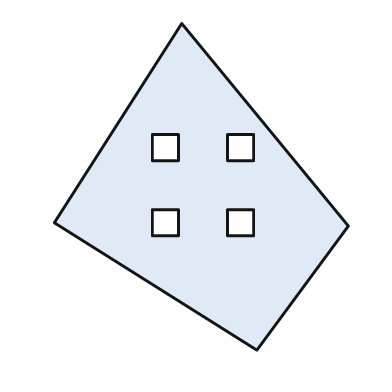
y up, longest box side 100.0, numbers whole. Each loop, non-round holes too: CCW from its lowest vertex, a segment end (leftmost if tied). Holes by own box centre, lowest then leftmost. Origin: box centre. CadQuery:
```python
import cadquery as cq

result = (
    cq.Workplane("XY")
    .moveTo(17.0, -50.0)
    .lineTo(45.0, -12.0)
    .lineTo(-6.0, 50.0)
    .lineTo(-45.0, -11.0)
    .close()
    .moveTo(-15.0, -15.0)
    .lineTo(-7.0, -15.0)
    .lineTo(-7.0, -7.0)
    .lineTo(-15.0, -7.0)
    .close()
    .moveTo(8.0, -15.0)
    .lineTo(16.0, -15.0)
    .lineTo(16.0, -7.0)
    .lineTo(8.0, -7.0)
    .close()
    .moveTo(-15.0, 8.0)
    .lineTo(-7.0, 8.0)
    .lineTo(-7.0, 16.0)
    .lineTo(-15.0, 16.0)
    .close()
    .moveTo(8.0, 8.0)
    .lineTo(16.0, 8.0)
    .lineTo(16.0, 16.0)
    .lineTo(8.0, 16.0)
    .close()
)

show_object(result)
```